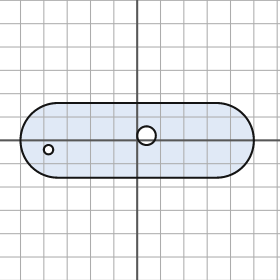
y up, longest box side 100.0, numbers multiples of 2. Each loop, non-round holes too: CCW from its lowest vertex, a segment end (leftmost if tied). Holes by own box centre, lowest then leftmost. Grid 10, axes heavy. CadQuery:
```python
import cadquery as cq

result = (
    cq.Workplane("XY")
    .moveTo(-34.0, -16.0)
    .lineTo(34.0, -16.0)
    .threePointArc((50.0, 0.0), (34.0, 16.0))
    .lineTo(-34.0, 16.0)
    .threePointArc((-50.0, 0.0), (-34.0, -16.0))
    .close()
    .moveTo(-38.0, -4.0)
    .circle(2.0)
    .moveTo(4.0, 2.0)
    .circle(4.0)
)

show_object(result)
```